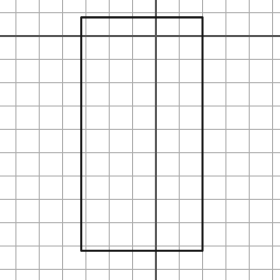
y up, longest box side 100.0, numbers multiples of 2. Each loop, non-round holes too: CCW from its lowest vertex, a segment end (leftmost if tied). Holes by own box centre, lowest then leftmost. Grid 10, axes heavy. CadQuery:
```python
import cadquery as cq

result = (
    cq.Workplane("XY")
    .moveTo(-32.0, -92.0)
    .lineTo(20.0, -92.0)
    .lineTo(20.0, 8.0)
    .lineTo(-32.0, 8.0)
    .close()
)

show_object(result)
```